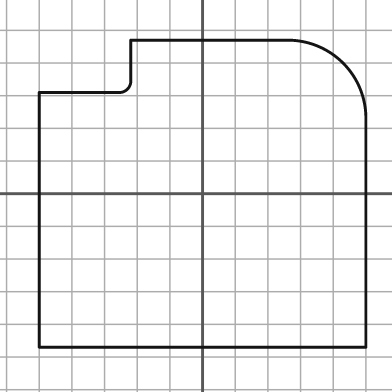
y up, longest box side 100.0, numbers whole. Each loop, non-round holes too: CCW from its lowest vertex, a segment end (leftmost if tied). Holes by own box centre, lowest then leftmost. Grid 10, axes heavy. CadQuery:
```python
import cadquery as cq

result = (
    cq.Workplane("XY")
    .moveTo(-50.0, -47.0)
    .lineTo(50.0, -47.0)
    .lineTo(50.0, 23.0)
    .threePointArc((43.0, 40.0), (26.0, 47.0))
    .lineTo(-22.0, 47.0)
    .lineTo(-22.0, 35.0)
    .threePointArc((-23.0, 32.0), (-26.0, 31.0))
    .lineTo(-50.0, 31.0)
    .close()
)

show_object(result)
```